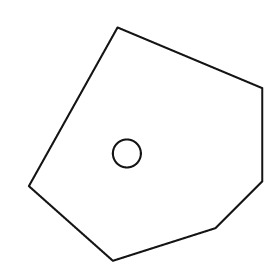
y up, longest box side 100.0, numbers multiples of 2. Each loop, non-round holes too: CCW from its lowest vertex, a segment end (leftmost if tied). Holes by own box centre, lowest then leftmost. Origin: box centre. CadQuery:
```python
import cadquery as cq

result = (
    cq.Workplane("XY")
    .moveTo(-14.0, -50.0)
    .lineTo(30.0, -36.0)
    .lineTo(50.0, -16.0)
    .lineTo(50.0, 24.0)
    .lineTo(-12.0, 50.0)
    .lineTo(-50.0, -18.0)
    .close()
    .moveTo(-8.0, -4.0)
    .circle(6.0)
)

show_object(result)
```